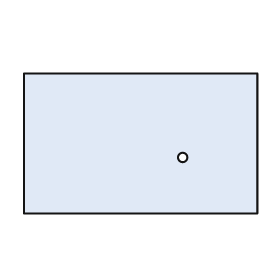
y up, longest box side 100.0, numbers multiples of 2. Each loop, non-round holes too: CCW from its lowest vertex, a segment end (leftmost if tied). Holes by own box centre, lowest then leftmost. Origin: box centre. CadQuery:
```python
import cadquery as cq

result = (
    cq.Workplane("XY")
    .moveTo(-50.0, -30.0)
    .lineTo(50.0, -30.0)
    .lineTo(50.0, 30.0)
    .lineTo(-50.0, 30.0)
    .close()
    .moveTo(18.0, -6.0)
    .circle(2.0)
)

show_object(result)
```